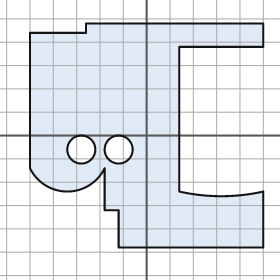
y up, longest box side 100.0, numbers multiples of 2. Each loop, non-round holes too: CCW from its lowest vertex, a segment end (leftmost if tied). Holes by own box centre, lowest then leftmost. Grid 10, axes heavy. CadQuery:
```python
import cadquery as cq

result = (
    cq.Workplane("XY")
    .moveTo(-12.0, -48.0)
    .lineTo(50.0, -48.0)
    .lineTo(50.0, -24.0)
    .threePointArc((32.0, -26.0), (14.0, -24.0))
    .lineTo(14.0, 38.0)
    .lineTo(50.0, 38.0)
    .lineTo(50.0, 48.0)
    .lineTo(-26.0, 48.0)
    .lineTo(-26.0, 44.0)
    .lineTo(-50.0, 44.0)
    .lineTo(-50.0, -14.0)
    .threePointArc((-34.0, -24.0), (-18.0, -14.0))
    .lineTo(-18.0, -32.0)
    .lineTo(-12.0, -32.0)
    .close()
    .moveTo(-28.0, -6.0)
    .circle(6.0)
    .moveTo(-12.0, -6.0)
    .circle(6.0)
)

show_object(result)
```